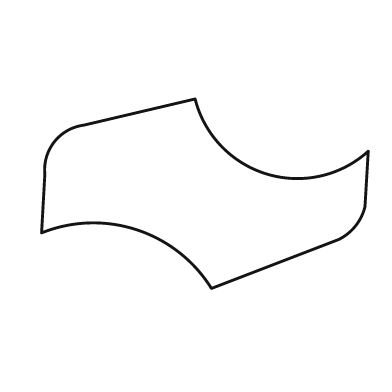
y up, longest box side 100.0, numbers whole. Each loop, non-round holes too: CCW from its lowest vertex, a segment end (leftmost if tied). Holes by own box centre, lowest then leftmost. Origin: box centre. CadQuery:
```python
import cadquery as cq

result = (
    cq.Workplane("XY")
    .moveTo(2.0, -29.0)
    .lineTo(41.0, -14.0)
    .threePointArc((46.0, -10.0), (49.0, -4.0))
    .lineTo(50.0, 13.0)
    .threePointArc((19.0, 6.0), (-3.0, 29.0))
    .lineTo(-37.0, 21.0)
    .threePointArc((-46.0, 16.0), (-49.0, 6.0))
    .lineTo(-50.0, -12.0)
    .threePointArc((-21.0, -11.0), (2.0, -29.0))
    .close()
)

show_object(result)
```